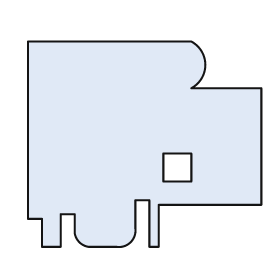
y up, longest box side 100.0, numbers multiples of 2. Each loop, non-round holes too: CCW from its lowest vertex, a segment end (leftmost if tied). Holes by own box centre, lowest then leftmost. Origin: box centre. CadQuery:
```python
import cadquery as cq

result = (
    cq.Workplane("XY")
    .moveTo(-44.0, -44.0)
    .lineTo(-36.0, -44.0)
    .lineTo(-36.0, -30.0)
    .lineTo(-30.0, -30.0)
    .lineTo(-30.0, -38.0)
    .threePointArc((-28.0, -42.0), (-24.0, -44.0))
    .lineTo(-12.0, -44.0)
    .threePointArc((-6.0, -42.0), (-4.0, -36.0))
    .lineTo(-4.0, -24.0)
    .lineTo(2.0, -24.0)
    .lineTo(2.0, -44.0)
    .lineTo(6.0, -44.0)
    .lineTo(6.0, -26.0)
    .lineTo(50.0, -26.0)
    .lineTo(50.0, 24.0)
    .lineTo(20.0, 24.0)
    .threePointArc((26.0, 34.0), (20.0, 44.0))
    .lineTo(-50.0, 44.0)
    .lineTo(-50.0, -32.0)
    .lineTo(-44.0, -32.0)
    .close()
    .moveTo(8.0, -16.0)
    .lineTo(20.0, -16.0)
    .lineTo(20.0, -4.0)
    .lineTo(8.0, -4.0)
    .close()
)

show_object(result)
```